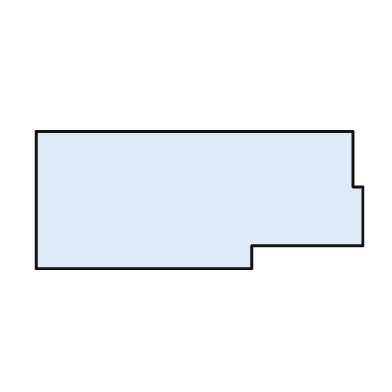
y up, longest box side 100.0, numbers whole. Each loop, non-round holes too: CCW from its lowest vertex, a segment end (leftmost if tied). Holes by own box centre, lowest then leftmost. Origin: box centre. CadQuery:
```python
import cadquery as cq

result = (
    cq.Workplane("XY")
    .moveTo(-50.0, -21.0)
    .lineTo(16.0, -21.0)
    .lineTo(16.0, -14.0)
    .lineTo(50.0, -14.0)
    .lineTo(50.0, 4.0)
    .lineTo(47.0, 4.0)
    .lineTo(47.0, 21.0)
    .lineTo(-50.0, 21.0)
    .close()
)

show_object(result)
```